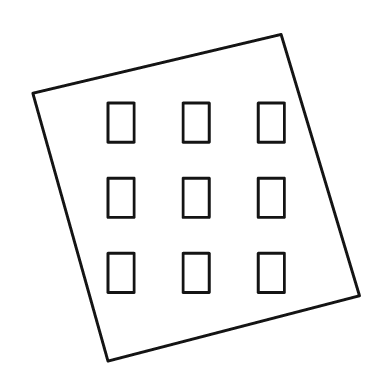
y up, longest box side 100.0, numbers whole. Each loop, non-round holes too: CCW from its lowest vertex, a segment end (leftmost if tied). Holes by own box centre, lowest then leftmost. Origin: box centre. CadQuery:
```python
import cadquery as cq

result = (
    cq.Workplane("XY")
    .moveTo(-27.0, -50.0)
    .lineTo(50.0, -30.0)
    .lineTo(26.0, 50.0)
    .lineTo(-50.0, 32.0)
    .close()
    .moveTo(-27.0, -29.0)
    .lineTo(-19.0, -29.0)
    .lineTo(-19.0, -17.0)
    .lineTo(-27.0, -17.0)
    .close()
    .moveTo(-4.0, -29.0)
    .lineTo(4.0, -29.0)
    .lineTo(4.0, -17.0)
    .lineTo(-4.0, -17.0)
    .close()
    .moveTo(19.0, -29.0)
    .lineTo(27.0, -29.0)
    .lineTo(27.0, -17.0)
    .lineTo(19.0, -17.0)
    .close()
    .moveTo(-27.0, -6.0)
    .lineTo(-19.0, -6.0)
    .lineTo(-19.0, 6.0)
    .lineTo(-27.0, 6.0)
    .close()
    .moveTo(-4.0, -6.0)
    .lineTo(4.0, -6.0)
    .lineTo(4.0, 6.0)
    .lineTo(-4.0, 6.0)
    .close()
    .moveTo(19.0, -6.0)
    .lineTo(27.0, -6.0)
    .lineTo(27.0, 6.0)
    .lineTo(19.0, 6.0)
    .close()
    .moveTo(-27.0, 17.0)
    .lineTo(-19.0, 17.0)
    .lineTo(-19.0, 29.0)
    .lineTo(-27.0, 29.0)
    .close()
    .moveTo(-4.0, 17.0)
    .lineTo(4.0, 17.0)
    .lineTo(4.0, 29.0)
    .lineTo(-4.0, 29.0)
    .close()
    .moveTo(19.0, 17.0)
    .lineTo(27.0, 17.0)
    .lineTo(27.0, 29.0)
    .lineTo(19.0, 29.0)
    .close()
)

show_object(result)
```